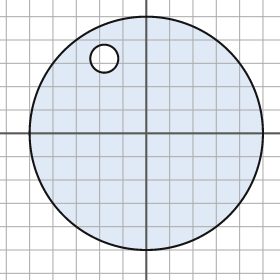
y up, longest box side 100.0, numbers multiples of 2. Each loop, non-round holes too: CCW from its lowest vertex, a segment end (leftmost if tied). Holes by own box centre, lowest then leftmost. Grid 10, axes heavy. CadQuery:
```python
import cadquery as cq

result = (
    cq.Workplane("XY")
    .moveTo(0.0, 0.0)
    .circle(50.0)
    .moveTo(-18.0, 32.0)
    .circle(6.0)
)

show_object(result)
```